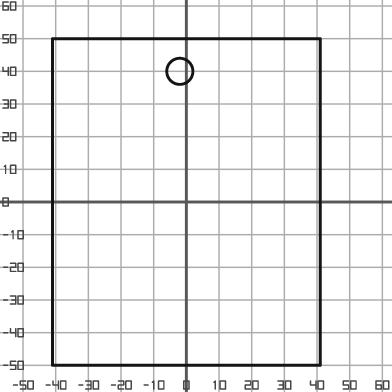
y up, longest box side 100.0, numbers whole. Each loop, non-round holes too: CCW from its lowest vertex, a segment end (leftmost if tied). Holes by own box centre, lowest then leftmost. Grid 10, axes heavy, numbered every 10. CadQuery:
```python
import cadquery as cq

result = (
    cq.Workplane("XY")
    .moveTo(-41.0, -50.0)
    .lineTo(41.0, -50.0)
    .lineTo(41.0, 50.0)
    .lineTo(-41.0, 50.0)
    .close()
    .moveTo(-2.0, 40.0)
    .circle(4.0)
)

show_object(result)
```